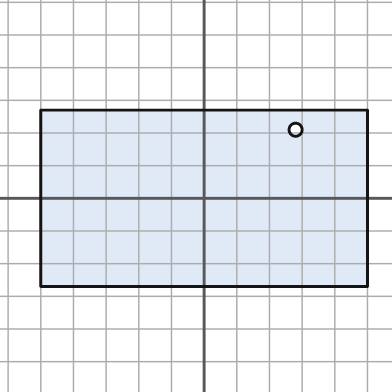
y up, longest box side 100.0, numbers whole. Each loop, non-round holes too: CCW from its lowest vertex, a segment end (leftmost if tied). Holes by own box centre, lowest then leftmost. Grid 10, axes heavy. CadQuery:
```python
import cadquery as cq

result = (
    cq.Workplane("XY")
    .moveTo(-50.0, -27.0)
    .lineTo(50.0, -27.0)
    .lineTo(50.0, 27.0)
    .lineTo(-50.0, 27.0)
    .close()
    .moveTo(28.0, 21.0)
    .circle(2.0)
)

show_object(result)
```